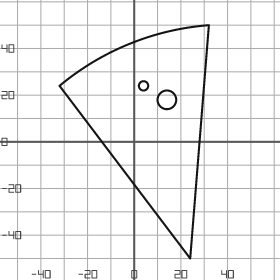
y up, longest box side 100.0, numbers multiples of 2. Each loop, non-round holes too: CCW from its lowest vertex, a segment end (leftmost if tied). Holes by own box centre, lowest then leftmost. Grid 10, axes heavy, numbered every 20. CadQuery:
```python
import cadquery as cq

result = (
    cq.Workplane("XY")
    .moveTo(24.0, -50.0)
    .lineTo(32.0, 50.0)
    .threePointArc((-2.0, 42.0), (-32.0, 24.0))
    .close()
    .moveTo(14.0, 18.0)
    .circle(4.0)
    .moveTo(4.0, 24.0)
    .circle(2.0)
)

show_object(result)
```